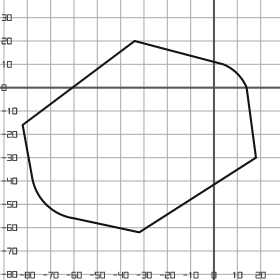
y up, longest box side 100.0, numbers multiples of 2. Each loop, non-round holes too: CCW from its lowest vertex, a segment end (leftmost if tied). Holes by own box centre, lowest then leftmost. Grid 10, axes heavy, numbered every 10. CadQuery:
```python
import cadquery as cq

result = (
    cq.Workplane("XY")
    .moveTo(-32.0, -62.0)
    .lineTo(18.0, -30.0)
    .lineTo(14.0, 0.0)
    .threePointArc((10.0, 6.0), (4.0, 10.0))
    .lineTo(-34.0, 20.0)
    .lineTo(-82.0, -16.0)
    .lineTo(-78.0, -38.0)
    .threePointArc((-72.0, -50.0), (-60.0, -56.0))
    .close()
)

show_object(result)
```